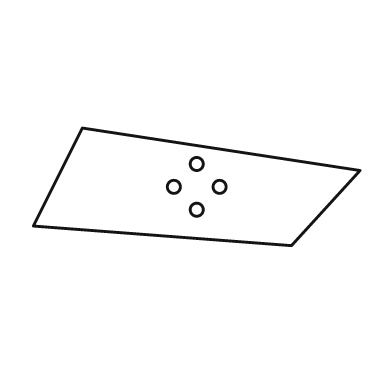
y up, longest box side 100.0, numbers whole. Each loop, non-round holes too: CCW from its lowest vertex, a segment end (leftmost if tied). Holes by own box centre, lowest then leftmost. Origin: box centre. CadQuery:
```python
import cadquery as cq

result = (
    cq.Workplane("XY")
    .moveTo(29.0, -18.0)
    .lineTo(50.0, 5.0)
    .lineTo(-35.0, 18.0)
    .lineTo(-50.0, -12.0)
    .close()
    .moveTo(0.0, -7.0)
    .circle(2.0)
    .moveTo(-7.0, 0.0)
    .circle(2.0)
    .moveTo(7.0, 0.0)
    .circle(2.0)
    .moveTo(0.0, 7.0)
    .circle(2.0)
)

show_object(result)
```